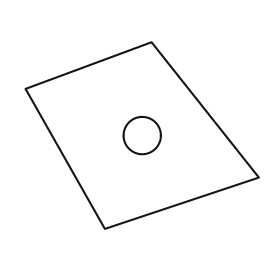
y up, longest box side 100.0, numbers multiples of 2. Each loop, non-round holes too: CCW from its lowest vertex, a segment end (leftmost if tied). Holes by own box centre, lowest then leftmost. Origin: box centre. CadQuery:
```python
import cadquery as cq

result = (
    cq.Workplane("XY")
    .moveTo(-16.0, -40.0)
    .lineTo(50.0, -18.0)
    .lineTo(4.0, 40.0)
    .lineTo(-50.0, 20.0)
    .close()
    .moveTo(0.0, 0.0)
    .circle(8.0)
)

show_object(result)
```